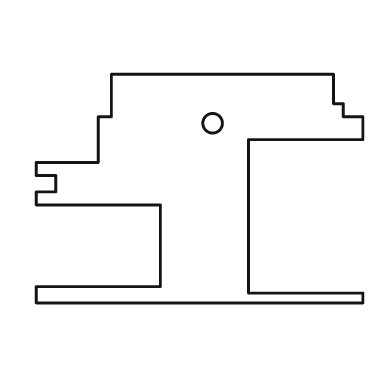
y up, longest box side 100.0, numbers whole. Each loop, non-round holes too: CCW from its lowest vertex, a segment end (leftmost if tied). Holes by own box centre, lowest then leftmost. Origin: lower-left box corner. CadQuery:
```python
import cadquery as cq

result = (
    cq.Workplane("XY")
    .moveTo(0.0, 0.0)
    .lineTo(100.0, 0.0)
    .lineTo(100.0, 3.0)
    .lineTo(65.0, 3.0)
    .lineTo(65.0, 50.0)
    .lineTo(100.0, 50.0)
    .lineTo(100.0, 57.0)
    .lineTo(94.0, 57.0)
    .lineTo(94.0, 61.0)
    .lineTo(91.0, 61.0)
    .lineTo(91.0, 70.0)
    .lineTo(23.0, 70.0)
    .lineTo(23.0, 57.0)
    .lineTo(19.0, 57.0)
    .lineTo(19.0, 43.0)
    .lineTo(0.0, 43.0)
    .lineTo(0.0, 39.0)
    .lineTo(6.0, 39.0)
    .lineTo(6.0, 34.0)
    .lineTo(0.0, 34.0)
    .lineTo(0.0, 30.0)
    .lineTo(38.0, 30.0)
    .lineTo(38.0, 5.0)
    .lineTo(0.0, 5.0)
    .close()
    .moveTo(54.0, 55.0)
    .circle(3.0)
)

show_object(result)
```